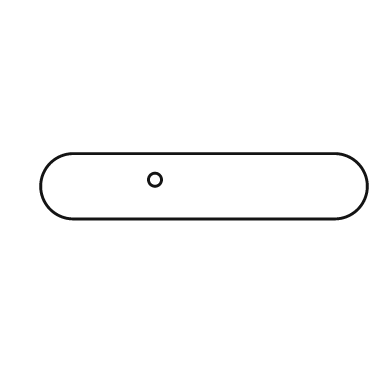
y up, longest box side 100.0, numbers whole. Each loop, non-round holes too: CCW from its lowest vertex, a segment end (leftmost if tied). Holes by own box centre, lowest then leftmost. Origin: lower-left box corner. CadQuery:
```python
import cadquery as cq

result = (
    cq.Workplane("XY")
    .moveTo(10.0, 0.0)
    .lineTo(90.0, 0.0)
    .threePointArc((100.0, 10.0), (90.0, 20.0))
    .lineTo(10.0, 20.0)
    .threePointArc((0.0, 10.0), (10.0, 0.0))
    .close()
    .moveTo(35.0, 12.0)
    .circle(2.0)
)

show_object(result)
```